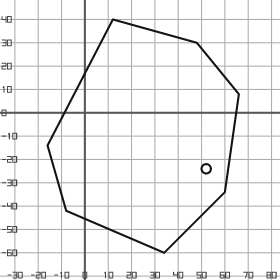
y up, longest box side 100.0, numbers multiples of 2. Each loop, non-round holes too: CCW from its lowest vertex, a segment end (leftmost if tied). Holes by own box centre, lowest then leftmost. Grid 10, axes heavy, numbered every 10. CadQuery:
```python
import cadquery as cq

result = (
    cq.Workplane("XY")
    .moveTo(34.0, -60.0)
    .lineTo(60.0, -34.0)
    .lineTo(66.0, 8.0)
    .lineTo(48.0, 30.0)
    .lineTo(12.0, 40.0)
    .lineTo(-16.0, -14.0)
    .lineTo(-8.0, -42.0)
    .close()
    .moveTo(52.0, -24.0)
    .circle(2.0)
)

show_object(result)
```